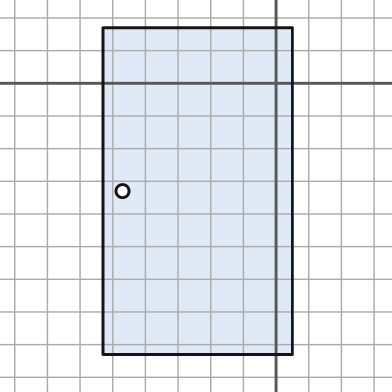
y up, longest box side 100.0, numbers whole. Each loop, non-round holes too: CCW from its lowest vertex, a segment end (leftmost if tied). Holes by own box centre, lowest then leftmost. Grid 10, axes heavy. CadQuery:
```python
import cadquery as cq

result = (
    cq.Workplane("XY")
    .moveTo(-53.0, -83.0)
    .lineTo(5.0, -83.0)
    .lineTo(5.0, 17.0)
    .lineTo(-53.0, 17.0)
    .close()
    .moveTo(-47.0, -33.0)
    .circle(2.0)
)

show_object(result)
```